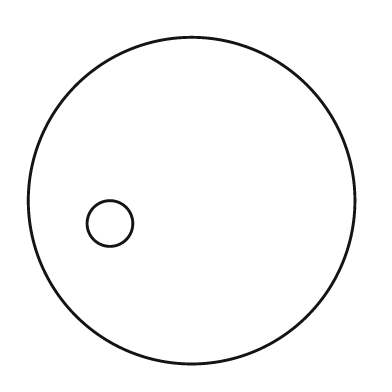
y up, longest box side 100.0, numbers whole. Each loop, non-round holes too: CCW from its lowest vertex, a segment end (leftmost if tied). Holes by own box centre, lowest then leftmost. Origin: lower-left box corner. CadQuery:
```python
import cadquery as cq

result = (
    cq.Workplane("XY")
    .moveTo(50.0, 50.0)
    .circle(50.0)
    .moveTo(25.0, 43.0)
    .circle(7.0)
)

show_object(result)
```